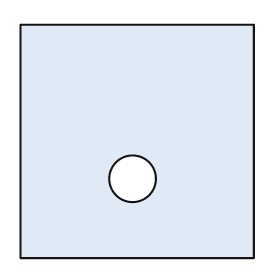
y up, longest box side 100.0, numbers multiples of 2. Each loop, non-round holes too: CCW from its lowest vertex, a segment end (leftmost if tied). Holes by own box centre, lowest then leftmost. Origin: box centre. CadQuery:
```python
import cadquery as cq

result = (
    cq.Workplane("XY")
    .moveTo(-50.0, -50.0)
    .lineTo(50.0, -50.0)
    .lineTo(50.0, 50.0)
    .lineTo(-50.0, 50.0)
    .close()
    .moveTo(-2.0, -16.0)
    .circle(10.0)
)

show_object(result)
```